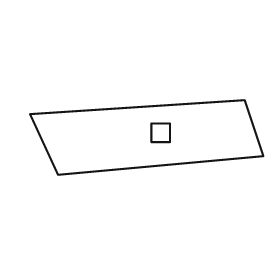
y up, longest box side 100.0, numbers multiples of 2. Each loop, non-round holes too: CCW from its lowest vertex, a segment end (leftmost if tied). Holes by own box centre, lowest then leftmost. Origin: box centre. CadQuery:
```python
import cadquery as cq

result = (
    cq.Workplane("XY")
    .moveTo(-38.0, -16.0)
    .lineTo(50.0, -8.0)
    .lineTo(42.0, 16.0)
    .lineTo(-50.0, 10.0)
    .close()
    .moveTo(2.0, -2.0)
    .lineTo(10.0, -2.0)
    .lineTo(10.0, 6.0)
    .lineTo(2.0, 6.0)
    .close()
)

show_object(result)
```